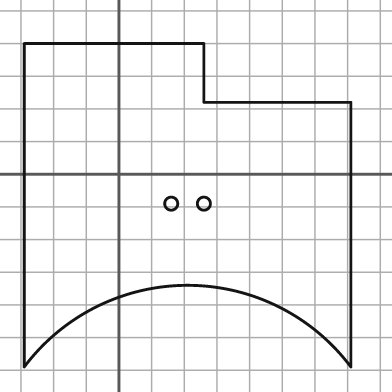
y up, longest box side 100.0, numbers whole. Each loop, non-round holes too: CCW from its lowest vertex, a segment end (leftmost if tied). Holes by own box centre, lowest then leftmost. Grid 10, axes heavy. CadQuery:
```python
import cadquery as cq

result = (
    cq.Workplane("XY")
    .moveTo(-29.0, -59.0)
    .threePointArc((21.0, -34.0), (71.0, -59.0))
    .lineTo(71.0, 22.0)
    .lineTo(26.0, 22.0)
    .lineTo(26.0, 40.0)
    .lineTo(-29.0, 40.0)
    .close()
    .moveTo(16.0, -9.0)
    .circle(2.0)
    .moveTo(26.0, -9.0)
    .circle(2.0)
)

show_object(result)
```